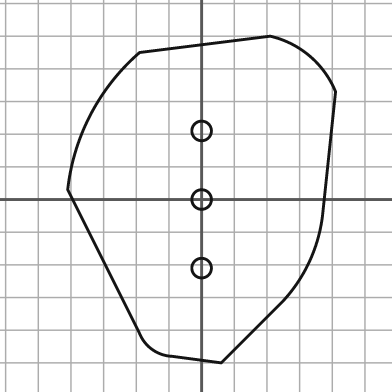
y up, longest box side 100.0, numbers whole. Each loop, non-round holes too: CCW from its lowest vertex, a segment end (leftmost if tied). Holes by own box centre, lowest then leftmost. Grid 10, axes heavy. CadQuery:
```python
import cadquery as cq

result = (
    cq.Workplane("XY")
    .moveTo(6.0, -50.0)
    .lineTo(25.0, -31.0)
    .threePointArc((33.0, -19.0), (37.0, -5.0))
    .lineTo(41.0, 33.0)
    .threePointArc((33.0, 44.0), (21.0, 50.0))
    .lineTo(-19.0, 45.0)
    .threePointArc((-34.0, 26.0), (-41.0, 3.0))
    .lineTo(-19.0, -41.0)
    .threePointArc((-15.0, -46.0), (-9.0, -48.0))
    .close()
    .moveTo(0.0, -21.0)
    .circle(3.0)
    .moveTo(0.0, 0.0)
    .circle(3.0)
    .moveTo(0.0, 21.0)
    .circle(3.0)
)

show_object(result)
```